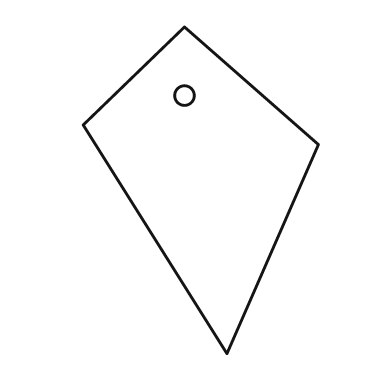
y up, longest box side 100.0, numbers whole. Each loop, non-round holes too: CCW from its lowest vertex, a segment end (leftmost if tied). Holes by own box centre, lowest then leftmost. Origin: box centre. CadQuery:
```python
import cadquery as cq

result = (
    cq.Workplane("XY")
    .moveTo(8.0, -50.0)
    .lineTo(36.0, 14.0)
    .lineTo(-5.0, 50.0)
    .lineTo(-36.0, 20.0)
    .close()
    .moveTo(-5.0, 29.0)
    .circle(3.0)
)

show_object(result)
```